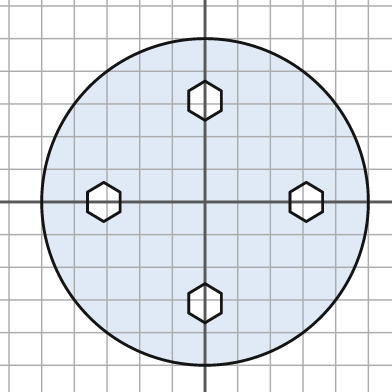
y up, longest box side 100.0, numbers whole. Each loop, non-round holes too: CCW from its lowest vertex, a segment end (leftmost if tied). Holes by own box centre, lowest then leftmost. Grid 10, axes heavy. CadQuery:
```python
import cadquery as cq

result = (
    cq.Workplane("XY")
    .moveTo(0.0, 0.0)
    .circle(50.0)
    .moveTo(0.0, -37.0)
    .lineTo(5.0, -34.0)
    .lineTo(5.0, -28.0)
    .lineTo(0.0, -25.0)
    .lineTo(-5.0, -28.0)
    .lineTo(-5.0, -34.0)
    .close()
    .moveTo(-31.0, -6.0)
    .lineTo(-26.0, -3.0)
    .lineTo(-26.0, 3.0)
    .lineTo(-31.0, 6.0)
    .lineTo(-36.0, 3.0)
    .lineTo(-36.0, -3.0)
    .close()
    .moveTo(31.0, -6.0)
    .lineTo(36.0, -3.0)
    .lineTo(36.0, 3.0)
    .lineTo(31.0, 6.0)
    .lineTo(26.0, 3.0)
    .lineTo(26.0, -3.0)
    .close()
    .moveTo(0.0, 25.0)
    .lineTo(5.0, 28.0)
    .lineTo(5.0, 34.0)
    .lineTo(0.0, 37.0)
    .lineTo(-5.0, 34.0)
    .lineTo(-5.0, 28.0)
    .close()
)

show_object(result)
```